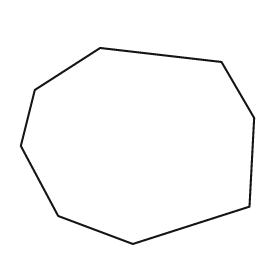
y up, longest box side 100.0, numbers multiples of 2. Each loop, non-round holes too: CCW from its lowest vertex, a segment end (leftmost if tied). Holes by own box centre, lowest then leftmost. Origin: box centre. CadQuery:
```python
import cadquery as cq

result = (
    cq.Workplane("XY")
    .moveTo(-2.0, -42.0)
    .lineTo(48.0, -26.0)
    .lineTo(50.0, 12.0)
    .lineTo(36.0, 36.0)
    .lineTo(-16.0, 42.0)
    .lineTo(-44.0, 24.0)
    .lineTo(-50.0, 0.0)
    .lineTo(-34.0, -30.0)
    .close()
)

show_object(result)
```